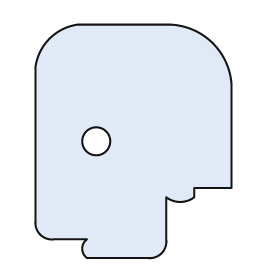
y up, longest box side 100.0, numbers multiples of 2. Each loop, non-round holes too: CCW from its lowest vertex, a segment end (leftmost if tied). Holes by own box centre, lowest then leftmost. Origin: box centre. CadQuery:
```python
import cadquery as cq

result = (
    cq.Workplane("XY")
    .moveTo(-20.0, -50.0)
    .lineTo(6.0, -50.0)
    .threePointArc((12.0, -48.0), (14.0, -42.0))
    .lineTo(14.0, -24.0)
    .threePointArc((20.0, -26.0), (26.0, -24.0))
    .lineTo(26.0, -20.0)
    .lineTo(42.0, -20.0)
    .lineTo(42.0, 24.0)
    .threePointArc((34.0, 42.0), (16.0, 50.0))
    .lineTo(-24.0, 50.0)
    .threePointArc((-36.0, 44.0), (-42.0, 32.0))
    .lineTo(-42.0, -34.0)
    .threePointArc((-40.0, -40.0), (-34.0, -42.0))
    .lineTo(-20.0, -42.0)
    .threePointArc((-22.0, -46.0), (-20.0, -50.0))
    .close()
    .moveTo(-16.0, 0.0)
    .circle(6.0)
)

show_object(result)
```